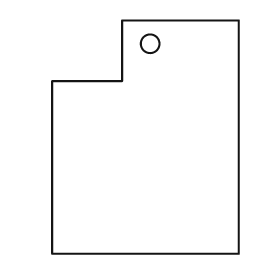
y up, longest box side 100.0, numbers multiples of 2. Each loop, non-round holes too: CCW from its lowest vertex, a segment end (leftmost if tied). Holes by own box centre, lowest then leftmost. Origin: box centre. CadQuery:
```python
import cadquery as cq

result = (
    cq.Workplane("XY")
    .moveTo(-40.0, -50.0)
    .lineTo(40.0, -50.0)
    .lineTo(40.0, 50.0)
    .lineTo(-10.0, 50.0)
    .lineTo(-10.0, 24.0)
    .lineTo(-40.0, 24.0)
    .close()
    .moveTo(2.0, 40.0)
    .circle(4.0)
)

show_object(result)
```